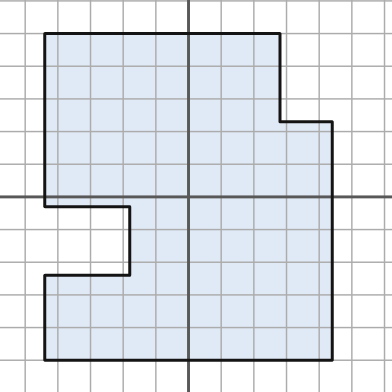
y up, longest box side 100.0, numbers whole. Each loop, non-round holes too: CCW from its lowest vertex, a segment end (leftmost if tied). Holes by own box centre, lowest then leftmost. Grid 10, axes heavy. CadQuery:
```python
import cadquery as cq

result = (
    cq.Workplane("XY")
    .moveTo(-44.0, -50.0)
    .lineTo(44.0, -50.0)
    .lineTo(44.0, 23.0)
    .lineTo(28.0, 23.0)
    .lineTo(28.0, 50.0)
    .lineTo(-44.0, 50.0)
    .lineTo(-44.0, -3.0)
    .lineTo(-18.0, -3.0)
    .lineTo(-18.0, -24.0)
    .lineTo(-44.0, -24.0)
    .close()
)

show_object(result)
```